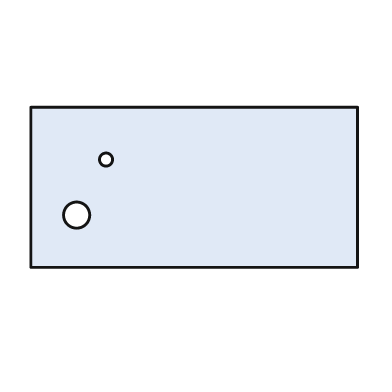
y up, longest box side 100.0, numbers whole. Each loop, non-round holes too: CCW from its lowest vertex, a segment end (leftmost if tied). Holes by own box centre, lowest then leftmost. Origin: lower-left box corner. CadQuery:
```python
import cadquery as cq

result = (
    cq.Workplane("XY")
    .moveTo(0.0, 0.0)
    .lineTo(100.0, 0.0)
    .lineTo(100.0, 49.0)
    .lineTo(0.0, 49.0)
    .close()
    .moveTo(14.0, 16.0)
    .circle(4.0)
    .moveTo(23.0, 33.0)
    .circle(2.0)
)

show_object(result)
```